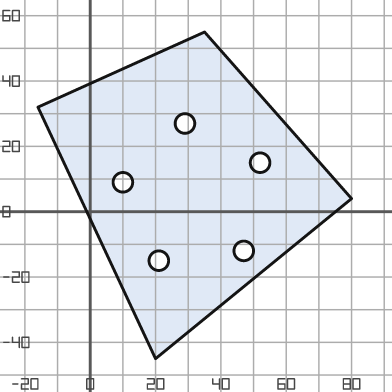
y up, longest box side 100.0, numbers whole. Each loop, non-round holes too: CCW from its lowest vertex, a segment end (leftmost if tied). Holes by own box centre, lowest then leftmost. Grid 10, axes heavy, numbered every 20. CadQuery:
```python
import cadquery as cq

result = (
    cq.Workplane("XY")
    .moveTo(20.0, -45.0)
    .lineTo(80.0, 4.0)
    .lineTo(35.0, 55.0)
    .lineTo(-16.0, 32.0)
    .close()
    .moveTo(21.0, -15.0)
    .circle(3.0)
    .moveTo(47.0, -12.0)
    .circle(3.0)
    .moveTo(10.0, 9.0)
    .circle(3.0)
    .moveTo(52.0, 15.0)
    .circle(3.0)
    .moveTo(29.0, 27.0)
    .circle(3.0)
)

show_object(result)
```